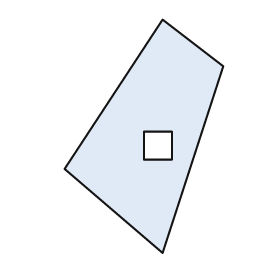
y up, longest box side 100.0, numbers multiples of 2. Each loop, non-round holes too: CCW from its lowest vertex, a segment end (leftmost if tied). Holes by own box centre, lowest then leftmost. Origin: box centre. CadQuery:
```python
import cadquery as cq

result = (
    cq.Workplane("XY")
    .moveTo(8.0, -50.0)
    .lineTo(34.0, 30.0)
    .lineTo(8.0, 50.0)
    .lineTo(-34.0, -14.0)
    .close()
    .moveTo(0.0, -10.0)
    .lineTo(12.0, -10.0)
    .lineTo(12.0, 2.0)
    .lineTo(0.0, 2.0)
    .close()
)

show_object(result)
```